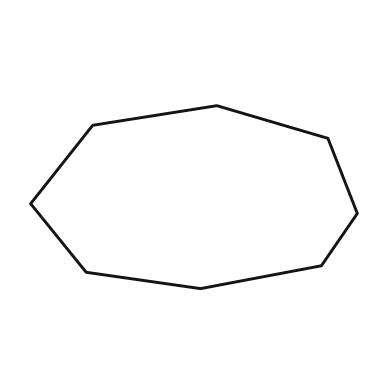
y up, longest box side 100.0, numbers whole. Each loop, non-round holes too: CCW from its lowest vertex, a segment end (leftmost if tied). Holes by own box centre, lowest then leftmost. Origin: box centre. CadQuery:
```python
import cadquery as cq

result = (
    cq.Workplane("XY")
    .moveTo(2.0, -28.0)
    .lineTo(39.0, -21.0)
    .lineTo(50.0, -5.0)
    .lineTo(41.0, 18.0)
    .lineTo(7.0, 28.0)
    .lineTo(-31.0, 22.0)
    .lineTo(-50.0, -2.0)
    .lineTo(-33.0, -23.0)
    .close()
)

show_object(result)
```